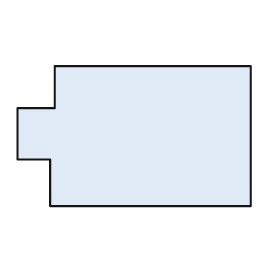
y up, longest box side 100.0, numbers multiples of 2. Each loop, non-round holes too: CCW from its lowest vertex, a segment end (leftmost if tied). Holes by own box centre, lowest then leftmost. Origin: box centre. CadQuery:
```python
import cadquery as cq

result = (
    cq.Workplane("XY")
    .moveTo(-36.0, -30.0)
    .lineTo(50.0, -30.0)
    .lineTo(50.0, 30.0)
    .lineTo(-34.0, 30.0)
    .lineTo(-34.0, 12.0)
    .lineTo(-50.0, 12.0)
    .lineTo(-50.0, -10.0)
    .lineTo(-36.0, -10.0)
    .close()
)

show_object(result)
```